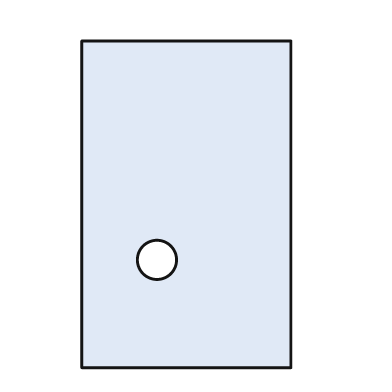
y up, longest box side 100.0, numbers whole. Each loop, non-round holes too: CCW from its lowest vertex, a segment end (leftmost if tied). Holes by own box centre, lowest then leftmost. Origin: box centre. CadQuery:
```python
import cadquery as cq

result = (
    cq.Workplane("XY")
    .moveTo(-32.0, -50.0)
    .lineTo(32.0, -50.0)
    .lineTo(32.0, 50.0)
    .lineTo(-32.0, 50.0)
    .close()
    .moveTo(-9.0, -17.0)
    .circle(6.0)
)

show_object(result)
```